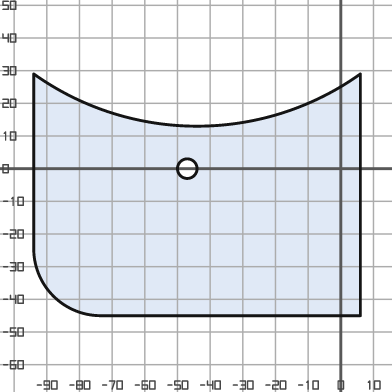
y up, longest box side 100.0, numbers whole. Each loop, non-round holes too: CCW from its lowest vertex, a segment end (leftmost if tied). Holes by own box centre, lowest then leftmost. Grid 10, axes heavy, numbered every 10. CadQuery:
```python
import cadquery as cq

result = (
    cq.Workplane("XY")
    .moveTo(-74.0, -45.0)
    .lineTo(6.0, -45.0)
    .lineTo(6.0, 29.0)
    .threePointArc((-44.0, 13.0), (-94.0, 29.0))
    .lineTo(-94.0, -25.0)
    .threePointArc((-88.0, -39.0), (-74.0, -45.0))
    .close()
    .moveTo(-47.0, 0.0)
    .circle(3.0)
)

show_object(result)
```